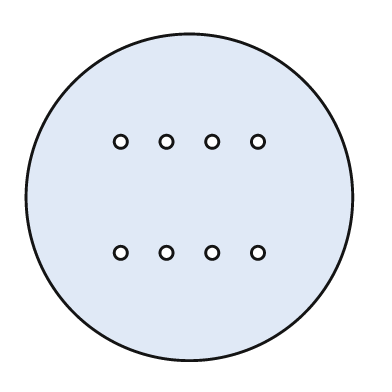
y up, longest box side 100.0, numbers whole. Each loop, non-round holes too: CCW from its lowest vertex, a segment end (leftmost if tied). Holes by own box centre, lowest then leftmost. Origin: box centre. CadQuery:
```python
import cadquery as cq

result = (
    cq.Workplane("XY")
    .moveTo(0.0, 0.0)
    .circle(50.0)
    .moveTo(-21.0, -17.0)
    .circle(2.0)
    .moveTo(-7.0, -17.0)
    .circle(2.0)
    .moveTo(7.0, -17.0)
    .circle(2.0)
    .moveTo(21.0, -17.0)
    .circle(2.0)
    .moveTo(-21.0, 17.0)
    .circle(2.0)
    .moveTo(-7.0, 17.0)
    .circle(2.0)
    .moveTo(7.0, 17.0)
    .circle(2.0)
    .moveTo(21.0, 17.0)
    .circle(2.0)
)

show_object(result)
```